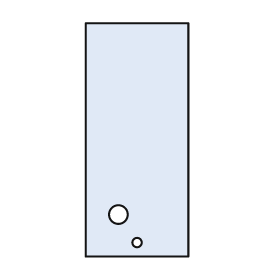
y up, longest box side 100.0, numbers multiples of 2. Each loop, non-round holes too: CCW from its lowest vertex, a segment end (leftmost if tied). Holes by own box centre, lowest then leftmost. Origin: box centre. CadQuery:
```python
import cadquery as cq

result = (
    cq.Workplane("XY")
    .moveTo(-22.0, -50.0)
    .lineTo(22.0, -50.0)
    .lineTo(22.0, 50.0)
    .lineTo(-22.0, 50.0)
    .close()
    .moveTo(0.0, -44.0)
    .circle(2.0)
    .moveTo(-8.0, -32.0)
    .circle(4.0)
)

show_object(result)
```